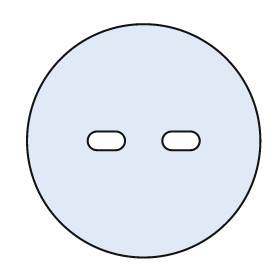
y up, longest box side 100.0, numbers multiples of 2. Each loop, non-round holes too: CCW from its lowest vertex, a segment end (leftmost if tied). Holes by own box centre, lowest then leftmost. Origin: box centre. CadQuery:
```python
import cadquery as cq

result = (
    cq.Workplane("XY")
    .moveTo(0.0, 0.0)
    .circle(50.0)
    .moveTo(-20.0, -4.0)
    .lineTo(-12.0, -4.0)
    .threePointArc((-8.0, 0.0), (-12.0, 4.0))
    .lineTo(-20.0, 4.0)
    .threePointArc((-24.0, 0.0), (-20.0, -4.0))
    .close()
    .moveTo(12.0, -4.0)
    .lineTo(20.0, -4.0)
    .threePointArc((24.0, 0.0), (20.0, 4.0))
    .lineTo(12.0, 4.0)
    .threePointArc((8.0, 0.0), (12.0, -4.0))
    .close()
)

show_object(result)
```